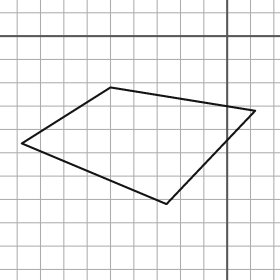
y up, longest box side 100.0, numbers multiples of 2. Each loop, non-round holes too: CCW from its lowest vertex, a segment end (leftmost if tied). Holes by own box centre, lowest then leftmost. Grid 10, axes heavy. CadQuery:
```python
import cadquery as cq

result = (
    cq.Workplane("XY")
    .moveTo(-26.0, -72.0)
    .lineTo(12.0, -32.0)
    .lineTo(-50.0, -22.0)
    .lineTo(-88.0, -46.0)
    .close()
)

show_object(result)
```